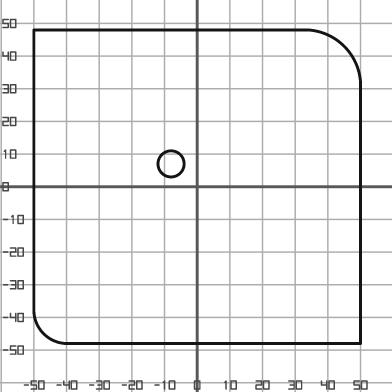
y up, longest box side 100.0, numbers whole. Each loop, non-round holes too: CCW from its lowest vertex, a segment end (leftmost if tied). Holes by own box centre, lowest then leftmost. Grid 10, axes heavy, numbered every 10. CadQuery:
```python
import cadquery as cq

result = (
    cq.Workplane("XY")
    .moveTo(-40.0, -48.0)
    .lineTo(50.0, -48.0)
    .lineTo(50.0, 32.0)
    .threePointArc((45.0, 43.0), (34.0, 48.0))
    .lineTo(-50.0, 48.0)
    .lineTo(-50.0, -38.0)
    .threePointArc((-47.0, -45.0), (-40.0, -48.0))
    .close()
    .moveTo(-8.0, 7.0)
    .circle(4.0)
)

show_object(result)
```